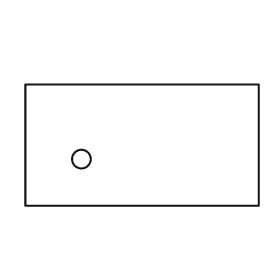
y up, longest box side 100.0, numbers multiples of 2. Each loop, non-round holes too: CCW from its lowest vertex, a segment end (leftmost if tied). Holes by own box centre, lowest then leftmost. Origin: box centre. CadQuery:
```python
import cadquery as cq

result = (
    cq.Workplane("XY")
    .moveTo(-50.0, -26.0)
    .lineTo(50.0, -26.0)
    .lineTo(50.0, 26.0)
    .lineTo(-50.0, 26.0)
    .close()
    .moveTo(-26.0, -6.0)
    .circle(4.0)
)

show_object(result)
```